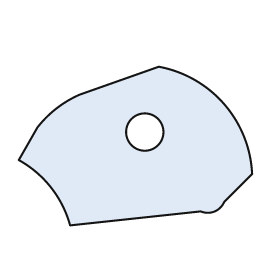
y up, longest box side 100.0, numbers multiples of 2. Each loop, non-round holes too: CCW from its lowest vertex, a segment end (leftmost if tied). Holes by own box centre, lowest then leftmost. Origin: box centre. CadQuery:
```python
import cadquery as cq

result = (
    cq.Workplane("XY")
    .moveTo(-28.0, -34.0)
    .lineTo(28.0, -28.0)
    .threePointArc((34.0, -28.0), (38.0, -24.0))
    .lineTo(50.0, -12.0)
    .threePointArc((38.0, 18.0), (10.0, 34.0))
    .lineTo(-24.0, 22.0)
    .threePointArc((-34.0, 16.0), (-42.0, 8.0))
    .lineTo(-50.0, -6.0)
    .threePointArc((-36.0, -18.0), (-28.0, -34.0))
    .close()
    .moveTo(4.0, 6.0)
    .circle(8.0)
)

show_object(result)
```